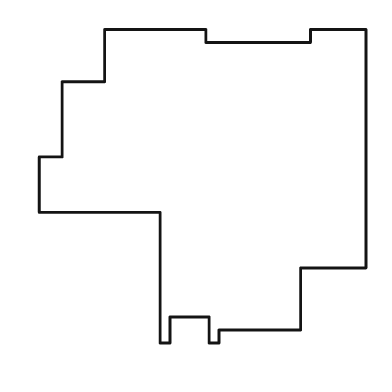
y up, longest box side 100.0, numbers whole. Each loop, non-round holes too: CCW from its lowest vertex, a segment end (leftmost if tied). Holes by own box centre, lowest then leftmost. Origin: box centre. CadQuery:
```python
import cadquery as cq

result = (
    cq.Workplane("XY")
    .moveTo(-13.0, -48.0)
    .lineTo(-10.0, -48.0)
    .lineTo(-10.0, -40.0)
    .lineTo(2.0, -40.0)
    .lineTo(2.0, -48.0)
    .lineTo(5.0, -48.0)
    .lineTo(5.0, -44.0)
    .lineTo(30.0, -44.0)
    .lineTo(30.0, -25.0)
    .lineTo(50.0, -25.0)
    .lineTo(50.0, 48.0)
    .lineTo(33.0, 48.0)
    .lineTo(33.0, 44.0)
    .lineTo(1.0, 44.0)
    .lineTo(1.0, 48.0)
    .lineTo(-30.0, 48.0)
    .lineTo(-30.0, 32.0)
    .lineTo(-43.0, 32.0)
    .lineTo(-43.0, 9.0)
    .lineTo(-50.0, 9.0)
    .lineTo(-50.0, -8.0)
    .lineTo(-13.0, -8.0)
    .close()
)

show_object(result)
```